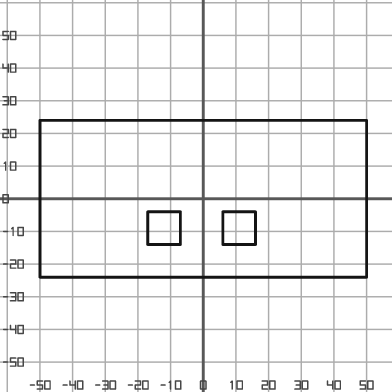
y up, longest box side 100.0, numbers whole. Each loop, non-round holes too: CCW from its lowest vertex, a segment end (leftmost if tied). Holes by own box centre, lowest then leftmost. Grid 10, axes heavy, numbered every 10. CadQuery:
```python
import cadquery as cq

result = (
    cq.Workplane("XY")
    .moveTo(-50.0, -24.0)
    .lineTo(50.0, -24.0)
    .lineTo(50.0, 24.0)
    .lineTo(-50.0, 24.0)
    .close()
    .moveTo(-17.0, -14.0)
    .lineTo(-7.0, -14.0)
    .lineTo(-7.0, -4.0)
    .lineTo(-17.0, -4.0)
    .close()
    .moveTo(6.0, -14.0)
    .lineTo(16.0, -14.0)
    .lineTo(16.0, -4.0)
    .lineTo(6.0, -4.0)
    .close()
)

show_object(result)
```